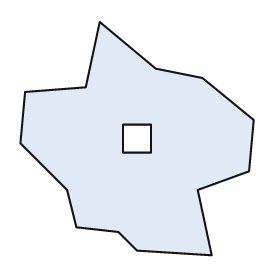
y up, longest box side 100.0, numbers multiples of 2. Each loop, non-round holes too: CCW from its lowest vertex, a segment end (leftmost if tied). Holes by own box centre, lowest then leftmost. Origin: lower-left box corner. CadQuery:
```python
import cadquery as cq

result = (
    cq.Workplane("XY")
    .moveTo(82.0, 0.0)
    .lineTo(76.0, 28.0)
    .lineTo(98.0, 36.0)
    .lineTo(100.0, 58.0)
    .lineTo(78.0, 76.0)
    .lineTo(58.0, 80.0)
    .lineTo(34.0, 100.0)
    .lineTo(28.0, 72.0)
    .lineTo(2.0, 70.0)
    .lineTo(0.0, 48.0)
    .lineTo(20.0, 28.0)
    .lineTo(24.0, 12.0)
    .lineTo(42.0, 10.0)
    .lineTo(50.0, 2.0)
    .close()
    .moveTo(44.0, 44.0)
    .lineTo(56.0, 44.0)
    .lineTo(56.0, 56.0)
    .lineTo(44.0, 56.0)
    .close()
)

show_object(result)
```